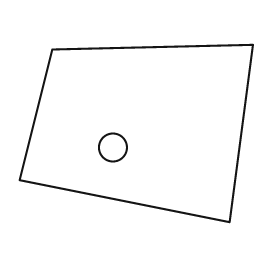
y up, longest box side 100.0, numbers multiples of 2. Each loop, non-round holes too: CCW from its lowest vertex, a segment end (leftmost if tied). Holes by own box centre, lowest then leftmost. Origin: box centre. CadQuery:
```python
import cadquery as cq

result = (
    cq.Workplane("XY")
    .moveTo(40.0, -38.0)
    .lineTo(50.0, 38.0)
    .lineTo(-36.0, 36.0)
    .lineTo(-50.0, -20.0)
    .close()
    .moveTo(-10.0, -6.0)
    .circle(6.0)
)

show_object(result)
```